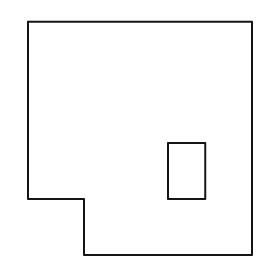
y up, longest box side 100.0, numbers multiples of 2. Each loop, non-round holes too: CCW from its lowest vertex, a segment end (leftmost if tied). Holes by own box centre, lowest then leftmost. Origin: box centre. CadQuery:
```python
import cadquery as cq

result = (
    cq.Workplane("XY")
    .moveTo(-24.0, -50.0)
    .lineTo(48.0, -50.0)
    .lineTo(48.0, 50.0)
    .lineTo(-48.0, 50.0)
    .lineTo(-48.0, -26.0)
    .lineTo(-24.0, -26.0)
    .close()
    .moveTo(12.0, -26.0)
    .lineTo(28.0, -26.0)
    .lineTo(28.0, -2.0)
    .lineTo(12.0, -2.0)
    .close()
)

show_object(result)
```